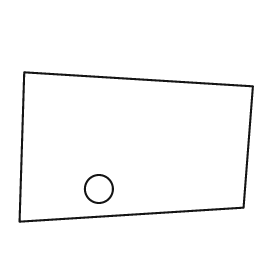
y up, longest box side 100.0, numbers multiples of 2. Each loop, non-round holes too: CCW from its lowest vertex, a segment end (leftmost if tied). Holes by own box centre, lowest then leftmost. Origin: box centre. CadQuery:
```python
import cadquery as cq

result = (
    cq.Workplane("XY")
    .moveTo(-50.0, -32.0)
    .lineTo(46.0, -26.0)
    .lineTo(50.0, 26.0)
    .lineTo(-48.0, 32.0)
    .close()
    .moveTo(-16.0, -18.0)
    .circle(6.0)
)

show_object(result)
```